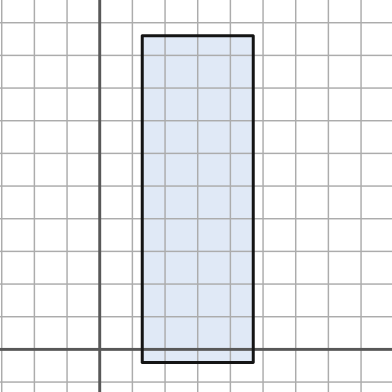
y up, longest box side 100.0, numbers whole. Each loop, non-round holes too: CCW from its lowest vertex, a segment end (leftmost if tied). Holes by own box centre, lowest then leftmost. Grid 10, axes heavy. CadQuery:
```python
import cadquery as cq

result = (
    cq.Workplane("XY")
    .moveTo(13.0, -4.0)
    .lineTo(47.0, -4.0)
    .lineTo(47.0, 96.0)
    .lineTo(13.0, 96.0)
    .close()
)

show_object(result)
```